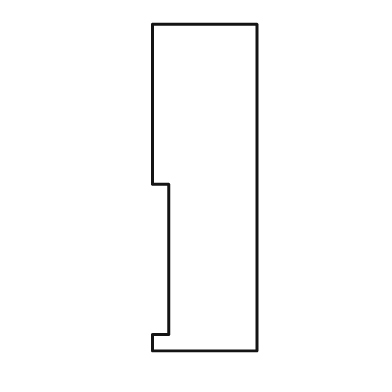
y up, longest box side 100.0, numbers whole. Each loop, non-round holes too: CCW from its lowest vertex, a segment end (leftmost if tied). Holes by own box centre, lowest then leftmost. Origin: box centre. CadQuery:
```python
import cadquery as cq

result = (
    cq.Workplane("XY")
    .moveTo(-16.0, -50.0)
    .lineTo(16.0, -50.0)
    .lineTo(16.0, 50.0)
    .lineTo(-16.0, 50.0)
    .lineTo(-16.0, 1.0)
    .lineTo(-11.0, 1.0)
    .lineTo(-11.0, -45.0)
    .lineTo(-16.0, -45.0)
    .close()
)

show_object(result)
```